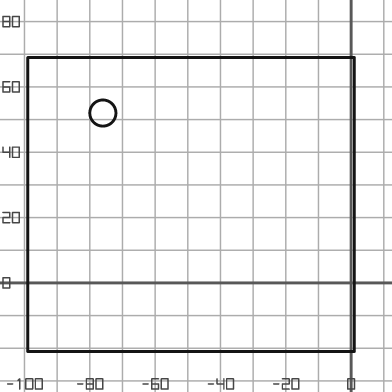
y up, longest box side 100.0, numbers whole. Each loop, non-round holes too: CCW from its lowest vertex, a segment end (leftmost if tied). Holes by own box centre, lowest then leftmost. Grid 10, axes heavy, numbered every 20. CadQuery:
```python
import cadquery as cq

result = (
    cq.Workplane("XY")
    .moveTo(-99.0, -21.0)
    .lineTo(1.0, -21.0)
    .lineTo(1.0, 69.0)
    .lineTo(-99.0, 69.0)
    .close()
    .moveTo(-76.0, 52.0)
    .circle(4.0)
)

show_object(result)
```